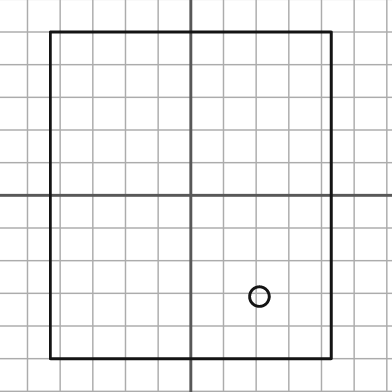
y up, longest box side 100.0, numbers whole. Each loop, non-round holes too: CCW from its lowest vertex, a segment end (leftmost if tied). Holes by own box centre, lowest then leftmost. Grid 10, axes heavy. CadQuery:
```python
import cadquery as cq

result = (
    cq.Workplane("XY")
    .moveTo(-43.0, -50.0)
    .lineTo(43.0, -50.0)
    .lineTo(43.0, 50.0)
    .lineTo(-43.0, 50.0)
    .close()
    .moveTo(21.0, -31.0)
    .circle(3.0)
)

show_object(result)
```